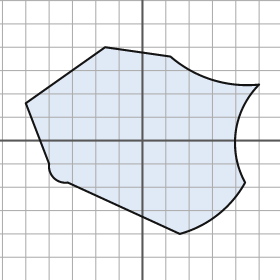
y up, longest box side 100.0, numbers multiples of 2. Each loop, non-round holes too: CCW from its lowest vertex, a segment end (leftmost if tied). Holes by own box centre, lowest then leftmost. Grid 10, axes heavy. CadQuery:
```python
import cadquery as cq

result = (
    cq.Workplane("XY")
    .moveTo(16.0, -40.0)
    .threePointArc((32.0, -32.0), (44.0, -18.0))
    .threePointArc((40.0, 4.0), (50.0, 24.0))
    .threePointArc((30.0, 26.0), (12.0, 36.0))
    .lineTo(-16.0, 40.0)
    .lineTo(-50.0, 16.0)
    .lineTo(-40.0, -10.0)
    .threePointArc((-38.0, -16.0), (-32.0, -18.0))
    .close()
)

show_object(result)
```